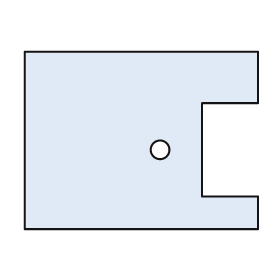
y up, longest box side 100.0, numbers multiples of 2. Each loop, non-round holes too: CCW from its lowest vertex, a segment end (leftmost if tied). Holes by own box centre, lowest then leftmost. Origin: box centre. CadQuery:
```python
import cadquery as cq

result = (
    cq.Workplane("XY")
    .moveTo(-50.0, -38.0)
    .lineTo(50.0, -38.0)
    .lineTo(50.0, -24.0)
    .lineTo(26.0, -24.0)
    .lineTo(26.0, 16.0)
    .lineTo(50.0, 16.0)
    .lineTo(50.0, 38.0)
    .lineTo(-50.0, 38.0)
    .close()
    .moveTo(8.0, -4.0)
    .circle(4.0)
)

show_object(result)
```